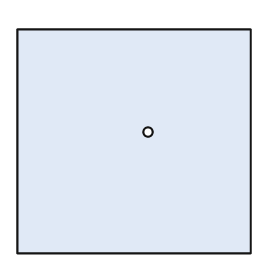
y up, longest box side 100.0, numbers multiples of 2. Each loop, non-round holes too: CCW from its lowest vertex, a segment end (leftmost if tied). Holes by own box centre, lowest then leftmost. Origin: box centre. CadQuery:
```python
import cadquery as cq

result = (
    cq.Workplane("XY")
    .moveTo(-50.0, -48.0)
    .lineTo(50.0, -48.0)
    .lineTo(50.0, 48.0)
    .lineTo(-50.0, 48.0)
    .close()
    .moveTo(6.0, 4.0)
    .circle(2.0)
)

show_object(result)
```